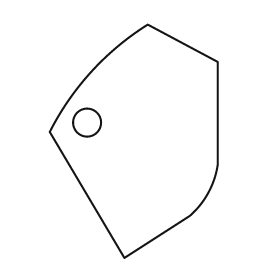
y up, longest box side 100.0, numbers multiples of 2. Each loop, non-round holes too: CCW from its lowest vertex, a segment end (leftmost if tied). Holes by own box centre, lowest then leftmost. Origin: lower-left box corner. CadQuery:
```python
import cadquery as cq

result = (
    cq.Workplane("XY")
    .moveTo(32.0, 0.0)
    .lineTo(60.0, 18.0)
    .threePointArc((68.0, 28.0), (72.0, 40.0))
    .lineTo(72.0, 84.0)
    .lineTo(42.0, 100.0)
    .threePointArc((18.0, 80.0), (0.0, 54.0))
    .close()
    .moveTo(16.0, 58.0)
    .circle(6.0)
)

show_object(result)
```